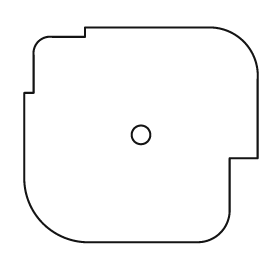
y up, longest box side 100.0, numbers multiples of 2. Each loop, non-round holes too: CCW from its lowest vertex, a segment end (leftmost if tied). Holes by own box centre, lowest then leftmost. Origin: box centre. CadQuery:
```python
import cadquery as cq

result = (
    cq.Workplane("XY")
    .moveTo(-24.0, -46.0)
    .lineTo(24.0, -46.0)
    .threePointArc((34.0, -42.0), (38.0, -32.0))
    .lineTo(38.0, -10.0)
    .lineTo(50.0, -10.0)
    .lineTo(50.0, 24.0)
    .threePointArc((44.0, 40.0), (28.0, 46.0))
    .lineTo(-24.0, 46.0)
    .lineTo(-24.0, 42.0)
    .lineTo(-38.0, 42.0)
    .threePointArc((-44.0, 40.0), (-46.0, 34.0))
    .lineTo(-46.0, 18.0)
    .lineTo(-50.0, 18.0)
    .lineTo(-50.0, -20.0)
    .threePointArc((-42.0, -38.0), (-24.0, -46.0))
    .close()
    .moveTo(0.0, 0.0)
    .circle(4.0)
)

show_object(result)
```